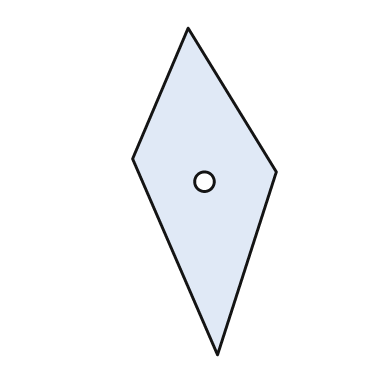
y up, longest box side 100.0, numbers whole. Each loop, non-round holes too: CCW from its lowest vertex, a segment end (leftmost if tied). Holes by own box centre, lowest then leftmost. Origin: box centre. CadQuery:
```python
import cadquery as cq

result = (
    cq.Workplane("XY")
    .moveTo(4.0, -50.0)
    .lineTo(22.0, 6.0)
    .lineTo(-5.0, 50.0)
    .lineTo(-22.0, 10.0)
    .close()
    .moveTo(0.0, 3.0)
    .circle(3.0)
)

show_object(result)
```